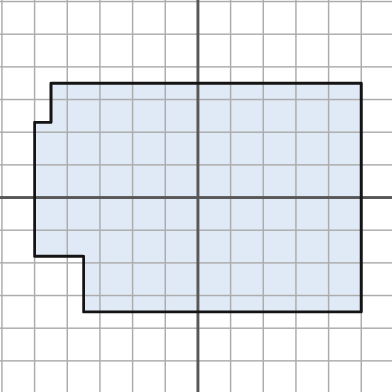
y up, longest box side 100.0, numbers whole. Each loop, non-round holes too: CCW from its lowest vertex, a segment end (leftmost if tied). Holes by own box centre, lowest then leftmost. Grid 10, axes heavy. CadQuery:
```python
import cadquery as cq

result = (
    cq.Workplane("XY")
    .moveTo(-35.0, -35.0)
    .lineTo(50.0, -35.0)
    .lineTo(50.0, 35.0)
    .lineTo(-45.0, 35.0)
    .lineTo(-45.0, 23.0)
    .lineTo(-50.0, 23.0)
    .lineTo(-50.0, -18.0)
    .lineTo(-35.0, -18.0)
    .close()
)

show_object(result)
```